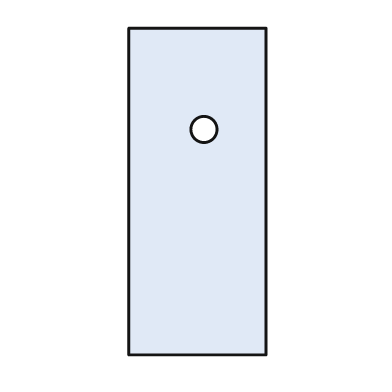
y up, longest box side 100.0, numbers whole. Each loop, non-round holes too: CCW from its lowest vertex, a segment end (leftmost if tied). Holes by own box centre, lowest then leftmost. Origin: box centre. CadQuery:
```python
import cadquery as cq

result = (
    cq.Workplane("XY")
    .moveTo(-21.0, -50.0)
    .lineTo(21.0, -50.0)
    .lineTo(21.0, 50.0)
    .lineTo(-21.0, 50.0)
    .close()
    .moveTo(2.0, 19.0)
    .circle(4.0)
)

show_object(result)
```